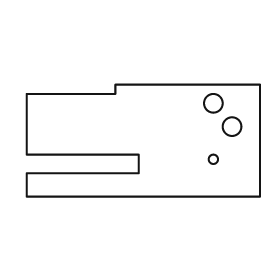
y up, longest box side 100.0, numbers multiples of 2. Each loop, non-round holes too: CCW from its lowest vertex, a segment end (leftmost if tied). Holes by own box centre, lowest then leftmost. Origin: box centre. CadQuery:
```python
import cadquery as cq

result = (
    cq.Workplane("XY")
    .moveTo(-50.0, -24.0)
    .lineTo(50.0, -24.0)
    .lineTo(50.0, 24.0)
    .lineTo(-12.0, 24.0)
    .lineTo(-12.0, 20.0)
    .lineTo(-50.0, 20.0)
    .lineTo(-50.0, -6.0)
    .lineTo(-2.0, -6.0)
    .lineTo(-2.0, -14.0)
    .lineTo(-50.0, -14.0)
    .close()
    .moveTo(30.0, -8.0)
    .circle(2.0)
    .moveTo(38.0, 6.0)
    .circle(4.0)
    .moveTo(30.0, 16.0)
    .circle(4.0)
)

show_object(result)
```